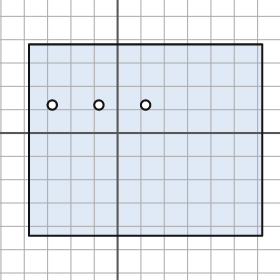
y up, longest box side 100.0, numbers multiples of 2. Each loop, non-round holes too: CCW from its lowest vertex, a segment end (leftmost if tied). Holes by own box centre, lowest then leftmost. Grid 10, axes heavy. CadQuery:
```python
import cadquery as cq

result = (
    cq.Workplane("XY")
    .moveTo(-38.0, -44.0)
    .lineTo(62.0, -44.0)
    .lineTo(62.0, 38.0)
    .lineTo(-38.0, 38.0)
    .close()
    .moveTo(-28.0, 12.0)
    .circle(2.0)
    .moveTo(-8.0, 12.0)
    .circle(2.0)
    .moveTo(12.0, 12.0)
    .circle(2.0)
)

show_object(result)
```